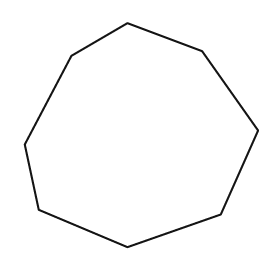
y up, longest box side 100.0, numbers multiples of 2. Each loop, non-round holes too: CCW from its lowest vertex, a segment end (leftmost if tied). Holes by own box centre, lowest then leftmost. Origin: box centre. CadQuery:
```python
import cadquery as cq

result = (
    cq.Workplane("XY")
    .moveTo(-6.0, -48.0)
    .lineTo(34.0, -34.0)
    .lineTo(50.0, 2.0)
    .lineTo(26.0, 36.0)
    .lineTo(-6.0, 48.0)
    .lineTo(-30.0, 34.0)
    .lineTo(-50.0, -4.0)
    .lineTo(-44.0, -32.0)
    .close()
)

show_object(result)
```